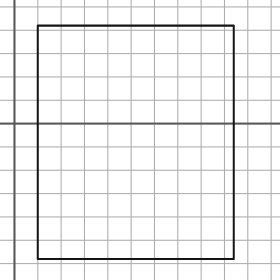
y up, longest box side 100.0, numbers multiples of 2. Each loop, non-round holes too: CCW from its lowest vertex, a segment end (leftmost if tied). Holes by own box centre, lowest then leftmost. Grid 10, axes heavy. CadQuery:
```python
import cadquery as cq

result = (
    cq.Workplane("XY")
    .moveTo(10.0, -58.0)
    .lineTo(94.0, -58.0)
    .lineTo(94.0, 42.0)
    .lineTo(10.0, 42.0)
    .close()
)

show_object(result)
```